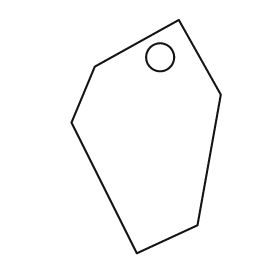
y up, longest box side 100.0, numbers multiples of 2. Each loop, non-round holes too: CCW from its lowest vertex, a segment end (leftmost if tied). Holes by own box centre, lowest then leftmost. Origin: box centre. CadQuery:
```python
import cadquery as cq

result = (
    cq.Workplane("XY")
    .moveTo(-4.0, -50.0)
    .lineTo(22.0, -38.0)
    .lineTo(32.0, 18.0)
    .lineTo(14.0, 50.0)
    .lineTo(-22.0, 30.0)
    .lineTo(-32.0, 6.0)
    .close()
    .moveTo(6.0, 34.0)
    .circle(6.0)
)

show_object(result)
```